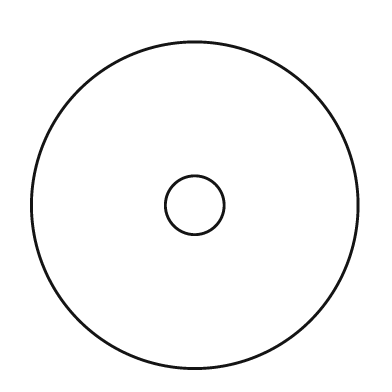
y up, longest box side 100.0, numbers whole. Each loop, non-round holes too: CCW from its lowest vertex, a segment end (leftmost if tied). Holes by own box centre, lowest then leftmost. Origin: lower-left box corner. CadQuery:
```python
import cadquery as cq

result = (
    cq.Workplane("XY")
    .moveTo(50.0, 50.0)
    .circle(50.0)
    .moveTo(50.0, 50.0)
    .circle(9.0)
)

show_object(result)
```